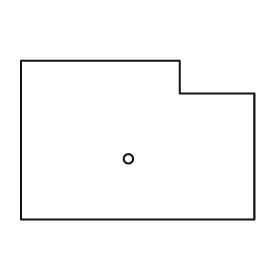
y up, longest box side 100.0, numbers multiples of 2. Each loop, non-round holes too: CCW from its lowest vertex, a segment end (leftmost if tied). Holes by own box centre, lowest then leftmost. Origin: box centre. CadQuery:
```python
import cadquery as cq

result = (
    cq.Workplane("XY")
    .moveTo(-50.0, -34.0)
    .lineTo(50.0, -34.0)
    .lineTo(50.0, 20.0)
    .lineTo(18.0, 20.0)
    .lineTo(18.0, 34.0)
    .lineTo(-50.0, 34.0)
    .close()
    .moveTo(-4.0, -8.0)
    .circle(2.0)
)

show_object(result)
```